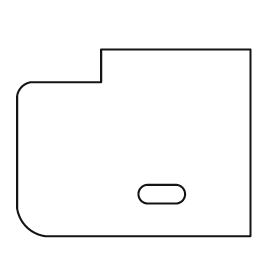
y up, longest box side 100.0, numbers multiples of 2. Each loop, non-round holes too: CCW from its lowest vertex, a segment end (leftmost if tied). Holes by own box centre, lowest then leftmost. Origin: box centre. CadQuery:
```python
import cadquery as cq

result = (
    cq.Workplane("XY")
    .moveTo(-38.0, -40.0)
    .lineTo(50.0, -40.0)
    .lineTo(50.0, 40.0)
    .lineTo(-14.0, 40.0)
    .lineTo(-14.0, 26.0)
    .lineTo(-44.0, 26.0)
    .threePointArc((-48.0, 24.0), (-50.0, 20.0))
    .lineTo(-50.0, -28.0)
    .threePointArc((-46.0, -36.0), (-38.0, -40.0))
    .close()
    .moveTo(6.0, -26.0)
    .lineTo(18.0, -26.0)
    .threePointArc((22.0, -22.0), (18.0, -18.0))
    .lineTo(6.0, -18.0)
    .threePointArc((2.0, -22.0), (6.0, -26.0))
    .close()
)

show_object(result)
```